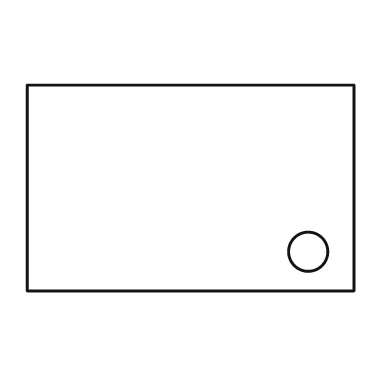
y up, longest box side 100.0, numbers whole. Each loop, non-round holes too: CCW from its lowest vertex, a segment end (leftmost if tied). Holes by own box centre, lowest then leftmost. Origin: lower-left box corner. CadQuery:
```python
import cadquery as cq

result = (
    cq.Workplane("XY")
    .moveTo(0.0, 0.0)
    .lineTo(100.0, 0.0)
    .lineTo(100.0, 63.0)
    .lineTo(0.0, 63.0)
    .close()
    .moveTo(86.0, 12.0)
    .circle(6.0)
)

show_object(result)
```